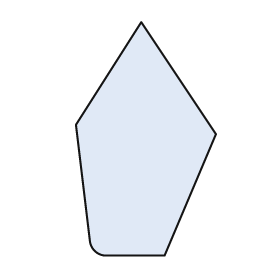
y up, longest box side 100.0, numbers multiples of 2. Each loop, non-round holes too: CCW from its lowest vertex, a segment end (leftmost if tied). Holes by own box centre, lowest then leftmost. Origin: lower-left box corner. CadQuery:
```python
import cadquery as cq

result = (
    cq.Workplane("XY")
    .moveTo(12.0, 0.0)
    .lineTo(38.0, 0.0)
    .lineTo(60.0, 52.0)
    .lineTo(28.0, 100.0)
    .lineTo(0.0, 56.0)
    .lineTo(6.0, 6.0)
    .threePointArc((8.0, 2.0), (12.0, 0.0))
    .close()
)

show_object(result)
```